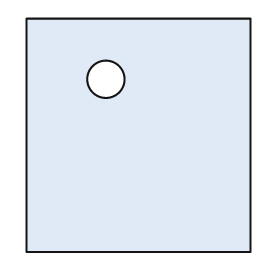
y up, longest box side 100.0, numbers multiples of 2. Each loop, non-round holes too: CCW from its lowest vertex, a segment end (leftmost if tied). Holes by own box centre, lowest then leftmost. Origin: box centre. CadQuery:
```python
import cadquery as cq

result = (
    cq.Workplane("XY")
    .moveTo(-48.0, -50.0)
    .lineTo(48.0, -50.0)
    .lineTo(48.0, 50.0)
    .lineTo(-48.0, 50.0)
    .close()
    .moveTo(-14.0, 24.0)
    .circle(8.0)
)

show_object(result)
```